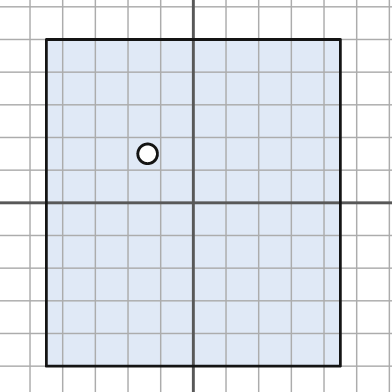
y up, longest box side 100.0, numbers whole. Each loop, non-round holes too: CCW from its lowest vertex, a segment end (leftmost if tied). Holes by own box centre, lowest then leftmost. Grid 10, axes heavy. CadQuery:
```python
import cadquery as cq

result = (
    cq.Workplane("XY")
    .moveTo(-45.0, -50.0)
    .lineTo(45.0, -50.0)
    .lineTo(45.0, 50.0)
    .lineTo(-45.0, 50.0)
    .close()
    .moveTo(-14.0, 15.0)
    .circle(3.0)
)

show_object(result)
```